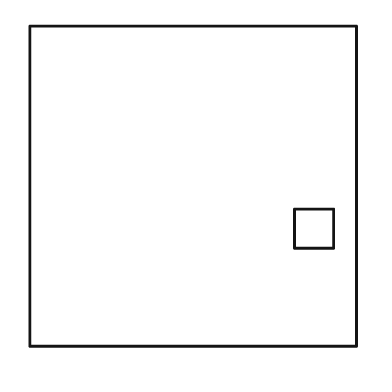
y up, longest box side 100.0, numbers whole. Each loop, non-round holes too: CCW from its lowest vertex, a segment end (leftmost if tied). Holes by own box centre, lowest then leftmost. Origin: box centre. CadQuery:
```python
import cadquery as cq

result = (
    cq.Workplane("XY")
    .moveTo(-50.0, -49.0)
    .lineTo(50.0, -49.0)
    .lineTo(50.0, 49.0)
    .lineTo(-50.0, 49.0)
    .close()
    .moveTo(31.0, -19.0)
    .lineTo(43.0, -19.0)
    .lineTo(43.0, -7.0)
    .lineTo(31.0, -7.0)
    .close()
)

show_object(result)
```